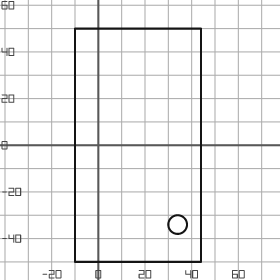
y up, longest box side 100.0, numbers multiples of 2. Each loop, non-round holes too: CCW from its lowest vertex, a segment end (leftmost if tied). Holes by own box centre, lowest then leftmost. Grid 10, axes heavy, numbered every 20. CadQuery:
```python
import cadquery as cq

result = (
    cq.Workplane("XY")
    .moveTo(-10.0, -50.0)
    .lineTo(44.0, -50.0)
    .lineTo(44.0, 50.0)
    .lineTo(-10.0, 50.0)
    .close()
    .moveTo(34.0, -34.0)
    .circle(4.0)
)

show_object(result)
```